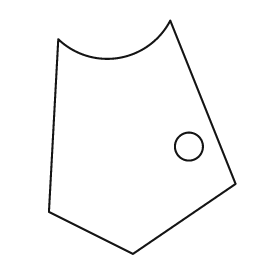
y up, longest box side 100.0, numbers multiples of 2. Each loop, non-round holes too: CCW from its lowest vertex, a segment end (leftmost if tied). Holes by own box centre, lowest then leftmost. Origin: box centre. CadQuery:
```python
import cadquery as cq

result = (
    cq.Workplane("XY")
    .moveTo(-4.0, -50.0)
    .lineTo(40.0, -20.0)
    .lineTo(12.0, 50.0)
    .threePointArc((-10.0, 34.0), (-36.0, 42.0))
    .lineTo(-40.0, -32.0)
    .close()
    .moveTo(20.0, -4.0)
    .circle(6.0)
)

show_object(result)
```